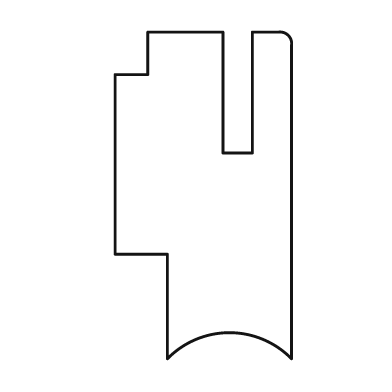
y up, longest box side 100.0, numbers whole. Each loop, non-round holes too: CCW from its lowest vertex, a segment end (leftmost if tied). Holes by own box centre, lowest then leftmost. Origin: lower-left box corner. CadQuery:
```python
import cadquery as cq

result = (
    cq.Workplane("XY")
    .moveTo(16.0, 0.0)
    .threePointArc((35.0, 8.0), (54.0, 0.0))
    .lineTo(54.0, 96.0)
    .threePointArc((53.0, 99.0), (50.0, 100.0))
    .lineTo(42.0, 100.0)
    .lineTo(42.0, 63.0)
    .lineTo(33.0, 63.0)
    .lineTo(33.0, 100.0)
    .lineTo(10.0, 100.0)
    .lineTo(10.0, 87.0)
    .lineTo(0.0, 87.0)
    .lineTo(0.0, 32.0)
    .lineTo(16.0, 32.0)
    .close()
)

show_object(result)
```